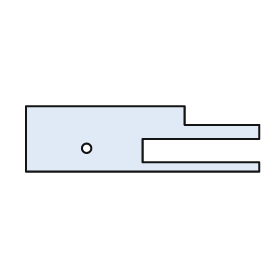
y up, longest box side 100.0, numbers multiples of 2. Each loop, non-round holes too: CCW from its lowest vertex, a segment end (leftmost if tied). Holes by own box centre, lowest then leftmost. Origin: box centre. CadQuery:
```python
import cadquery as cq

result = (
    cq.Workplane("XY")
    .moveTo(-50.0, -14.0)
    .lineTo(50.0, -14.0)
    .lineTo(50.0, -10.0)
    .lineTo(0.0, -10.0)
    .lineTo(0.0, 0.0)
    .lineTo(50.0, 0.0)
    .lineTo(50.0, 6.0)
    .lineTo(18.0, 6.0)
    .lineTo(18.0, 14.0)
    .lineTo(-50.0, 14.0)
    .close()
    .moveTo(-24.0, -4.0)
    .circle(2.0)
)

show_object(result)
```